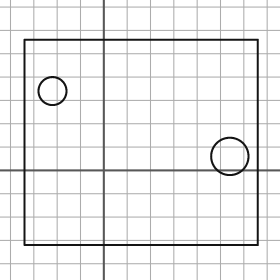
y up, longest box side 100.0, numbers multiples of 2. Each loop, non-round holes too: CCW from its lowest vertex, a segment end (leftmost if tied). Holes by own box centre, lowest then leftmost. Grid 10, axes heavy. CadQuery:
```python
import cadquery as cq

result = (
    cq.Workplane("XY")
    .moveTo(-34.0, -32.0)
    .lineTo(66.0, -32.0)
    .lineTo(66.0, 56.0)
    .lineTo(-34.0, 56.0)
    .close()
    .moveTo(54.0, 6.0)
    .circle(8.0)
    .moveTo(-22.0, 34.0)
    .circle(6.0)
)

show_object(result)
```